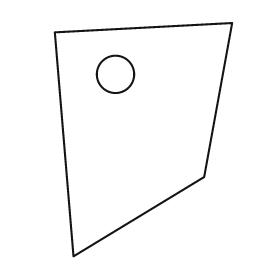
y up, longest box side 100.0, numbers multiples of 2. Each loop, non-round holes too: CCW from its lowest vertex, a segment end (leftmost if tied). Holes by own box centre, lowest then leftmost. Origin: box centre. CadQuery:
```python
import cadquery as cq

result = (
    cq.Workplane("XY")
    .moveTo(-30.0, -50.0)
    .lineTo(26.0, -16.0)
    .lineTo(38.0, 50.0)
    .lineTo(-38.0, 46.0)
    .close()
    .moveTo(-12.0, 28.0)
    .circle(8.0)
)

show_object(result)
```